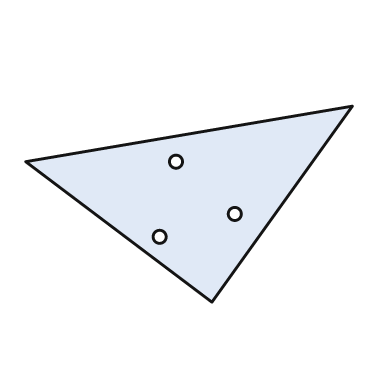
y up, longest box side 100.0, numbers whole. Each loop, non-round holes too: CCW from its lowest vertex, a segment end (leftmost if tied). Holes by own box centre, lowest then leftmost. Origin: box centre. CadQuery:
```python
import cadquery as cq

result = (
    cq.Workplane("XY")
    .moveTo(7.0, -30.0)
    .lineTo(50.0, 30.0)
    .lineTo(-50.0, 13.0)
    .close()
    .moveTo(-9.0, -10.0)
    .circle(2.0)
    .moveTo(14.0, -3.0)
    .circle(2.0)
    .moveTo(-4.0, 13.0)
    .circle(2.0)
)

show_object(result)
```